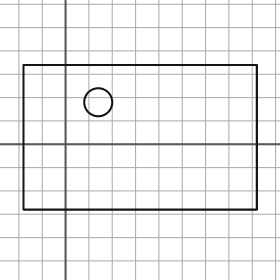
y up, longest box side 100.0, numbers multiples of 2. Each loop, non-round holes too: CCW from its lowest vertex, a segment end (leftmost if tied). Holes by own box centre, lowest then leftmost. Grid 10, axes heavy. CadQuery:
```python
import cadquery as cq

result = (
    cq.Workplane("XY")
    .moveTo(-18.0, -28.0)
    .lineTo(82.0, -28.0)
    .lineTo(82.0, 34.0)
    .lineTo(-18.0, 34.0)
    .close()
    .moveTo(14.0, 18.0)
    .circle(6.0)
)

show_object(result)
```